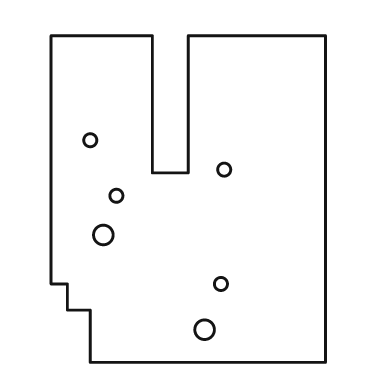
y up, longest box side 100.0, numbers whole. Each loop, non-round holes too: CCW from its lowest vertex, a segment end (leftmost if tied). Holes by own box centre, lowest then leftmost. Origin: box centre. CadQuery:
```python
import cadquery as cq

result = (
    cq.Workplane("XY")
    .moveTo(-30.0, -50.0)
    .lineTo(42.0, -50.0)
    .lineTo(42.0, 50.0)
    .lineTo(0.0, 50.0)
    .lineTo(0.0, 8.0)
    .lineTo(-11.0, 8.0)
    .lineTo(-11.0, 50.0)
    .lineTo(-42.0, 50.0)
    .lineTo(-42.0, -26.0)
    .lineTo(-37.0, -26.0)
    .lineTo(-37.0, -34.0)
    .lineTo(-30.0, -34.0)
    .close()
    .moveTo(5.0, -40.0)
    .circle(3.0)
    .moveTo(10.0, -26.0)
    .circle(2.0)
    .moveTo(-26.0, -11.0)
    .circle(3.0)
    .moveTo(-22.0, 1.0)
    .circle(2.0)
    .moveTo(11.0, 9.0)
    .circle(2.0)
    .moveTo(-30.0, 18.0)
    .circle(2.0)
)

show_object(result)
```